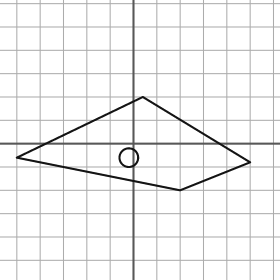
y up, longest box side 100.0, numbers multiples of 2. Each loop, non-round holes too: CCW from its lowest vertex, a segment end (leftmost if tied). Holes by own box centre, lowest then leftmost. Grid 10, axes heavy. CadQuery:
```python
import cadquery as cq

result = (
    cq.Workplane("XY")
    .moveTo(20.0, -20.0)
    .lineTo(50.0, -8.0)
    .lineTo(4.0, 20.0)
    .lineTo(-50.0, -6.0)
    .close()
    .moveTo(-2.0, -6.0)
    .circle(4.0)
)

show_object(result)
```